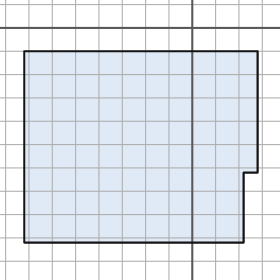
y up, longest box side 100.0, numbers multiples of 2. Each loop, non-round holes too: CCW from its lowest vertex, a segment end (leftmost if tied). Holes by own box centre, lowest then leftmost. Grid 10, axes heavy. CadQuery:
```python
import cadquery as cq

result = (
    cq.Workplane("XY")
    .moveTo(-72.0, -92.0)
    .lineTo(22.0, -92.0)
    .lineTo(22.0, -62.0)
    .lineTo(28.0, -62.0)
    .lineTo(28.0, -10.0)
    .lineTo(-72.0, -10.0)
    .close()
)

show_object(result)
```